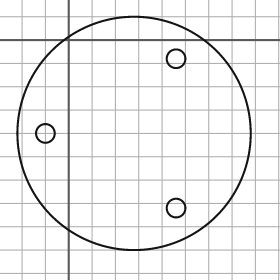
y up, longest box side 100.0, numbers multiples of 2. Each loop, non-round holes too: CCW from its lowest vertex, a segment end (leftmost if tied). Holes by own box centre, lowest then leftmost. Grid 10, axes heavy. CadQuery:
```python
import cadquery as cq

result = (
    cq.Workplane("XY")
    .moveTo(28.0, -40.0)
    .circle(50.0)
    .moveTo(46.0, -72.0)
    .circle(4.0)
    .moveTo(-10.0, -40.0)
    .circle(4.0)
    .moveTo(46.0, -8.0)
    .circle(4.0)
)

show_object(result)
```